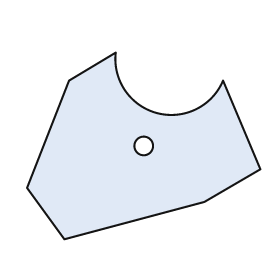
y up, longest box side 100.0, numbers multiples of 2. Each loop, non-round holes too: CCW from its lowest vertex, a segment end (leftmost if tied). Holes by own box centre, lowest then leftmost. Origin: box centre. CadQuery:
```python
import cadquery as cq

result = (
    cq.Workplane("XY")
    .moveTo(-34.0, -40.0)
    .lineTo(26.0, -24.0)
    .lineTo(50.0, -10.0)
    .lineTo(34.0, 28.0)
    .threePointArc((6.0, 14.0), (-12.0, 40.0))
    .lineTo(-32.0, 28.0)
    .lineTo(-50.0, -18.0)
    .close()
    .moveTo(0.0, 0.0)
    .circle(4.0)
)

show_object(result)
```